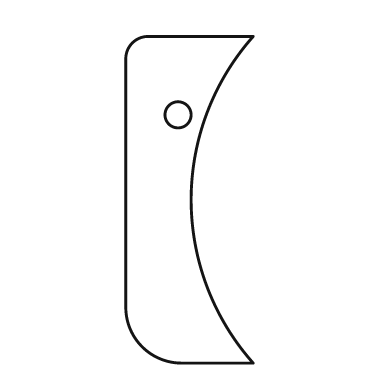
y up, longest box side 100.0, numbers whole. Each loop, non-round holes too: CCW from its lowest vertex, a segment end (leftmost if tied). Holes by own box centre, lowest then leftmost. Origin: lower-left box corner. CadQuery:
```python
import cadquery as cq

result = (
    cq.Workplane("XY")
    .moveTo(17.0, 0.0)
    .lineTo(39.0, 0.0)
    .threePointArc((20.0, 50.0), (39.0, 100.0))
    .lineTo(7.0, 100.0)
    .threePointArc((2.0, 98.0), (0.0, 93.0))
    .lineTo(0.0, 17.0)
    .threePointArc((5.0, 5.0), (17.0, 0.0))
    .close()
    .moveTo(16.0, 76.0)
    .circle(4.0)
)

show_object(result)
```